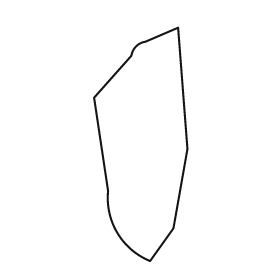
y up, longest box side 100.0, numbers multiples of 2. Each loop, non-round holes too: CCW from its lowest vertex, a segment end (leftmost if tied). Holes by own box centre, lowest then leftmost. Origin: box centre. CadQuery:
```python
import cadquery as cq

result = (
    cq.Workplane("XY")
    .moveTo(4.0, -50.0)
    .lineTo(14.0, -36.0)
    .lineTo(20.0, -2.0)
    .lineTo(16.0, 50.0)
    .lineTo(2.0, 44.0)
    .threePointArc((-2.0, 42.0), (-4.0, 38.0))
    .lineTo(-20.0, 20.0)
    .lineTo(-14.0, -20.0)
    .threePointArc((-10.0, -38.0), (4.0, -50.0))
    .close()
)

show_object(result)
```